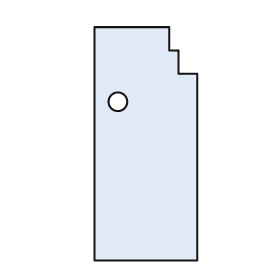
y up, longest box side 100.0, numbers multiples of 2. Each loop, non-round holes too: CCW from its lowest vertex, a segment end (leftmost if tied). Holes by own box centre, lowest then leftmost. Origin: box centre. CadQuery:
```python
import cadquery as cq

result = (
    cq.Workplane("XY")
    .moveTo(-22.0, -50.0)
    .lineTo(22.0, -50.0)
    .lineTo(22.0, 30.0)
    .lineTo(14.0, 30.0)
    .lineTo(14.0, 40.0)
    .lineTo(10.0, 40.0)
    .lineTo(10.0, 50.0)
    .lineTo(-22.0, 50.0)
    .close()
    .moveTo(-12.0, 18.0)
    .circle(4.0)
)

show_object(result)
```